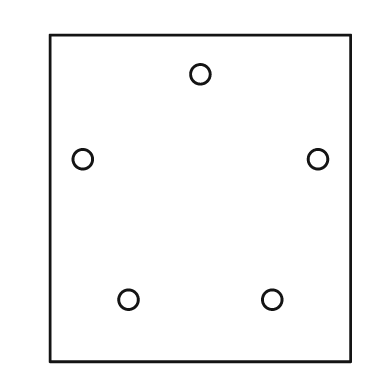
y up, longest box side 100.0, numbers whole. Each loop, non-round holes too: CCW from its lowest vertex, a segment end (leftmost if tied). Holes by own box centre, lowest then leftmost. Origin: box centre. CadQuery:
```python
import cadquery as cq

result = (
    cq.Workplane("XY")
    .moveTo(-46.0, -50.0)
    .lineTo(46.0, -50.0)
    .lineTo(46.0, 50.0)
    .lineTo(-46.0, 50.0)
    .close()
    .moveTo(-22.0, -31.0)
    .circle(3.0)
    .moveTo(22.0, -31.0)
    .circle(3.0)
    .moveTo(-36.0, 12.0)
    .circle(3.0)
    .moveTo(36.0, 12.0)
    .circle(3.0)
    .moveTo(0.0, 38.0)
    .circle(3.0)
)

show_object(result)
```